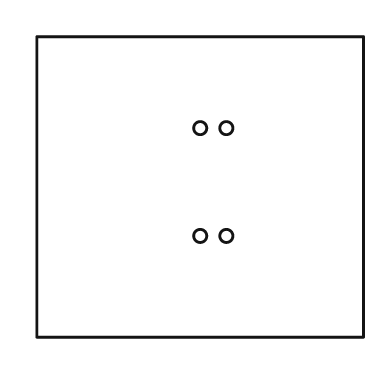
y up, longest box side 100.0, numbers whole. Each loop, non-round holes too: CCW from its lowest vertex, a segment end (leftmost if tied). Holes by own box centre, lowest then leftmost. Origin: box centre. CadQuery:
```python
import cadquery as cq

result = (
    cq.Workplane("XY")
    .moveTo(-50.0, -46.0)
    .lineTo(50.0, -46.0)
    .lineTo(50.0, 46.0)
    .lineTo(-50.0, 46.0)
    .close()
    .moveTo(0.0, -15.0)
    .circle(2.0)
    .moveTo(8.0, -15.0)
    .circle(2.0)
    .moveTo(0.0, 18.0)
    .circle(2.0)
    .moveTo(8.0, 18.0)
    .circle(2.0)
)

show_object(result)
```